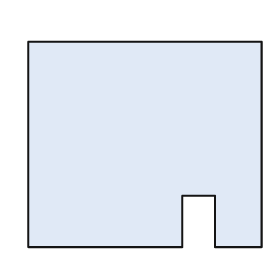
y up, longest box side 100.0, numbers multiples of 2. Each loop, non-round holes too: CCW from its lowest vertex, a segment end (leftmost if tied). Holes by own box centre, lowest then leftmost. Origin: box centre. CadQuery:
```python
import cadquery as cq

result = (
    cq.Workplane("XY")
    .moveTo(-50.0, -44.0)
    .lineTo(16.0, -44.0)
    .lineTo(16.0, -22.0)
    .lineTo(30.0, -22.0)
    .lineTo(30.0, -44.0)
    .lineTo(50.0, -44.0)
    .lineTo(50.0, 44.0)
    .lineTo(-50.0, 44.0)
    .close()
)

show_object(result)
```